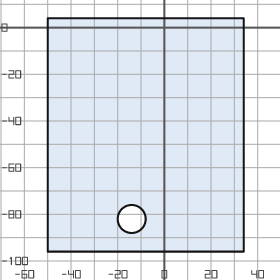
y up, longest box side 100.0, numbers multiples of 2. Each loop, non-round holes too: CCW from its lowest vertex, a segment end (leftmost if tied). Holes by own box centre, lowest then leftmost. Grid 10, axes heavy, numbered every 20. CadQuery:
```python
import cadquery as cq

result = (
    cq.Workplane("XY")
    .moveTo(-50.0, -96.0)
    .lineTo(34.0, -96.0)
    .lineTo(34.0, 4.0)
    .lineTo(-50.0, 4.0)
    .close()
    .moveTo(-14.0, -82.0)
    .circle(6.0)
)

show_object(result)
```